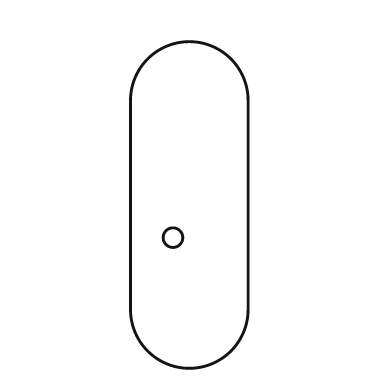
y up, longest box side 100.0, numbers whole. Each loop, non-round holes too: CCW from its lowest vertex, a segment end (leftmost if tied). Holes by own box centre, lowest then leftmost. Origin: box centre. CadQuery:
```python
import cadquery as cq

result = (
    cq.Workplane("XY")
    .moveTo(-18.0, -32.0)
    .threePointArc((0.0, -50.0), (18.0, -32.0))
    .lineTo(18.0, 32.0)
    .threePointArc((0.0, 50.0), (-18.0, 32.0))
    .close()
    .moveTo(-5.0, -10.0)
    .circle(3.0)
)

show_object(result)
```